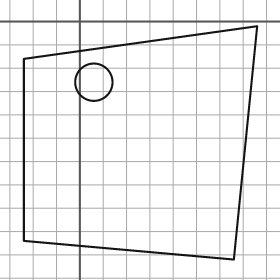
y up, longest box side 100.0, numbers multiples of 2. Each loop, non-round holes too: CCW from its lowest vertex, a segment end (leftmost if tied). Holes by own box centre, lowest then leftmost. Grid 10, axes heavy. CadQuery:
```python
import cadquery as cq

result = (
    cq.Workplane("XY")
    .moveTo(66.0, -102.0)
    .lineTo(76.0, -2.0)
    .lineTo(-24.0, -16.0)
    .lineTo(-24.0, -94.0)
    .close()
    .moveTo(6.0, -26.0)
    .circle(8.0)
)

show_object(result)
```